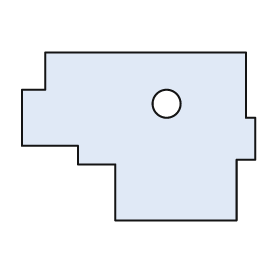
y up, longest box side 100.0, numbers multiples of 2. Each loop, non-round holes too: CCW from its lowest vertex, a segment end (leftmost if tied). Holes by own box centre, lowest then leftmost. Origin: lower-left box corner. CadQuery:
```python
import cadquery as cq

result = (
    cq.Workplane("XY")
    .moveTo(40.0, 0.0)
    .lineTo(92.0, 0.0)
    .lineTo(92.0, 26.0)
    .lineTo(100.0, 26.0)
    .lineTo(100.0, 44.0)
    .lineTo(96.0, 44.0)
    .lineTo(96.0, 72.0)
    .lineTo(10.0, 72.0)
    .lineTo(10.0, 56.0)
    .lineTo(0.0, 56.0)
    .lineTo(0.0, 32.0)
    .lineTo(24.0, 32.0)
    .lineTo(24.0, 24.0)
    .lineTo(40.0, 24.0)
    .close()
    .moveTo(62.0, 50.0)
    .circle(6.0)
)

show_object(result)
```